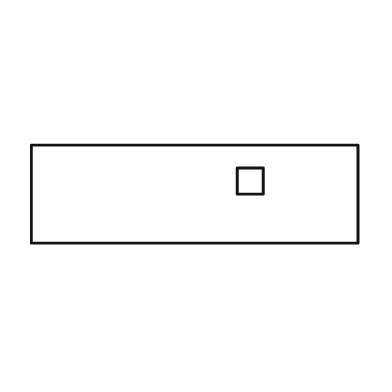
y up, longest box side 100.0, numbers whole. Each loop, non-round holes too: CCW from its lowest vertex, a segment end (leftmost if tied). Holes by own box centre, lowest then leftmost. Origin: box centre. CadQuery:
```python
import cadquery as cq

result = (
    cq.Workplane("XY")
    .moveTo(-50.0, -15.0)
    .lineTo(50.0, -15.0)
    .lineTo(50.0, 15.0)
    .lineTo(-50.0, 15.0)
    .close()
    .moveTo(13.0, 0.0)
    .lineTo(21.0, 0.0)
    .lineTo(21.0, 8.0)
    .lineTo(13.0, 8.0)
    .close()
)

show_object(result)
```